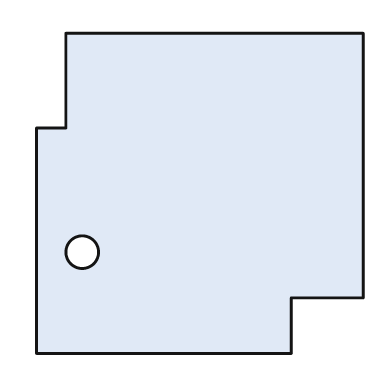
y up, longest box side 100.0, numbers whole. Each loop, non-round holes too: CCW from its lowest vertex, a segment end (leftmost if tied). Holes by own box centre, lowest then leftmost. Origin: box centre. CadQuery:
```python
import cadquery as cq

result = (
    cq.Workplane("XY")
    .moveTo(-50.0, -49.0)
    .lineTo(28.0, -49.0)
    .lineTo(28.0, -32.0)
    .lineTo(50.0, -32.0)
    .lineTo(50.0, 49.0)
    .lineTo(-41.0, 49.0)
    .lineTo(-41.0, 20.0)
    .lineTo(-50.0, 20.0)
    .close()
    .moveTo(-36.0, -18.0)
    .circle(5.0)
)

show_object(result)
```